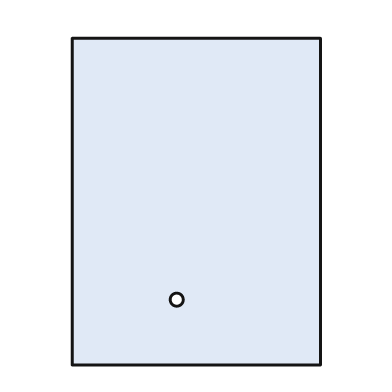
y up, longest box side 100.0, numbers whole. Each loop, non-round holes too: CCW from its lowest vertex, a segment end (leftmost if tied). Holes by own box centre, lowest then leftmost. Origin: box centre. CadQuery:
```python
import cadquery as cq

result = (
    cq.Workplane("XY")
    .moveTo(-38.0, -50.0)
    .lineTo(38.0, -50.0)
    .lineTo(38.0, 50.0)
    .lineTo(-38.0, 50.0)
    .close()
    .moveTo(-6.0, -30.0)
    .circle(2.0)
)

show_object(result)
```